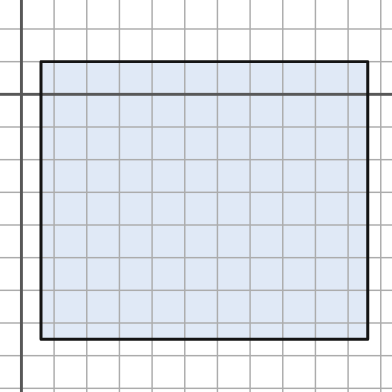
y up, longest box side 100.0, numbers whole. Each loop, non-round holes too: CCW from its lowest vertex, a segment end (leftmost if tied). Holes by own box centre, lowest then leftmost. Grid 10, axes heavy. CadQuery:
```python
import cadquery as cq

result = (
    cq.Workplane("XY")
    .moveTo(6.0, -75.0)
    .lineTo(106.0, -75.0)
    .lineTo(106.0, 10.0)
    .lineTo(6.0, 10.0)
    .close()
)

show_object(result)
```